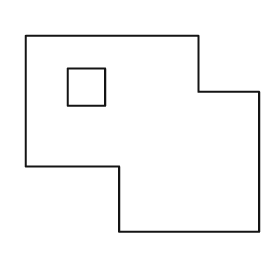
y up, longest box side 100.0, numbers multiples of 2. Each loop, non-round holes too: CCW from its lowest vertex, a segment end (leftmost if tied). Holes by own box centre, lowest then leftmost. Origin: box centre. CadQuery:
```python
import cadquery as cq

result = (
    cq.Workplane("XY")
    .moveTo(-10.0, -42.0)
    .lineTo(50.0, -42.0)
    .lineTo(50.0, 18.0)
    .lineTo(24.0, 18.0)
    .lineTo(24.0, 42.0)
    .lineTo(-50.0, 42.0)
    .lineTo(-50.0, -14.0)
    .lineTo(-10.0, -14.0)
    .close()
    .moveTo(-32.0, 12.0)
    .lineTo(-16.0, 12.0)
    .lineTo(-16.0, 28.0)
    .lineTo(-32.0, 28.0)
    .close()
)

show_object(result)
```